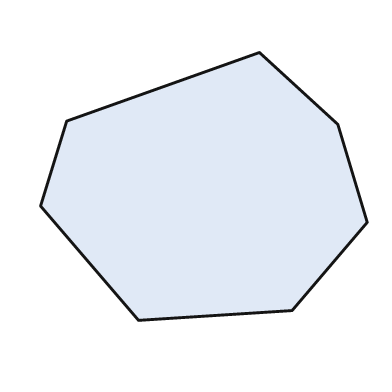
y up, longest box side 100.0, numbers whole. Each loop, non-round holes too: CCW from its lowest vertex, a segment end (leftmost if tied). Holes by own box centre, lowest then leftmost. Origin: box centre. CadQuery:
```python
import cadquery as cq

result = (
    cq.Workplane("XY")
    .moveTo(-20.0, -41.0)
    .lineTo(27.0, -38.0)
    .lineTo(50.0, -11.0)
    .lineTo(41.0, 19.0)
    .lineTo(17.0, 41.0)
    .lineTo(-42.0, 20.0)
    .lineTo(-50.0, -6.0)
    .close()
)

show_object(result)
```